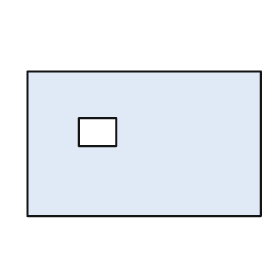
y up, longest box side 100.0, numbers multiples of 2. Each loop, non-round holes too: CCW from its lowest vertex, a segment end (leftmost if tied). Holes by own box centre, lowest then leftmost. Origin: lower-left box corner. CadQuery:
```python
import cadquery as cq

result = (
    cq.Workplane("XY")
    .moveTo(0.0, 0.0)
    .lineTo(100.0, 0.0)
    .lineTo(100.0, 62.0)
    .lineTo(0.0, 62.0)
    .close()
    .moveTo(22.0, 30.0)
    .lineTo(38.0, 30.0)
    .lineTo(38.0, 42.0)
    .lineTo(22.0, 42.0)
    .close()
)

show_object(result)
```